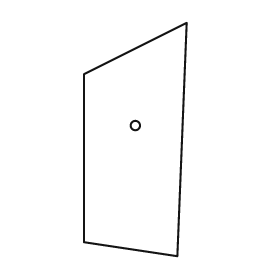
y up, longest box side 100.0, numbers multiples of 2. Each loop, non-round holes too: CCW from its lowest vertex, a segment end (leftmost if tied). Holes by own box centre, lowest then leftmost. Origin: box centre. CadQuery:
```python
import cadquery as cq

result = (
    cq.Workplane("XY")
    .moveTo(18.0, -50.0)
    .lineTo(22.0, 50.0)
    .lineTo(-22.0, 28.0)
    .lineTo(-22.0, -44.0)
    .close()
    .moveTo(0.0, 6.0)
    .circle(2.0)
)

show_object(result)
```